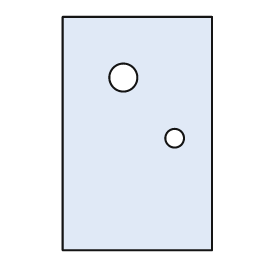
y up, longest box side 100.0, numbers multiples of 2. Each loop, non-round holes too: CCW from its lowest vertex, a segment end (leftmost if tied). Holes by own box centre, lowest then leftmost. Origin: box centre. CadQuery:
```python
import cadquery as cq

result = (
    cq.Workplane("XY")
    .moveTo(-32.0, -50.0)
    .lineTo(32.0, -50.0)
    .lineTo(32.0, 50.0)
    .lineTo(-32.0, 50.0)
    .close()
    .moveTo(16.0, -2.0)
    .circle(4.0)
    .moveTo(-6.0, 24.0)
    .circle(6.0)
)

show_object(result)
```